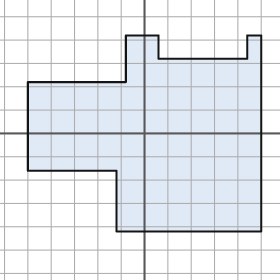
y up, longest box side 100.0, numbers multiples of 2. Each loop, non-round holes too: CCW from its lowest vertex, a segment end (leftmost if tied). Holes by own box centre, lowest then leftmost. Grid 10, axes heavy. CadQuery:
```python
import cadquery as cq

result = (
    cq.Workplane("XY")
    .moveTo(-12.0, -42.0)
    .lineTo(50.0, -42.0)
    .lineTo(50.0, 42.0)
    .lineTo(44.0, 42.0)
    .lineTo(44.0, 32.0)
    .lineTo(6.0, 32.0)
    .lineTo(6.0, 42.0)
    .lineTo(-8.0, 42.0)
    .lineTo(-8.0, 22.0)
    .lineTo(-50.0, 22.0)
    .lineTo(-50.0, -16.0)
    .lineTo(-12.0, -16.0)
    .close()
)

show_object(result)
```